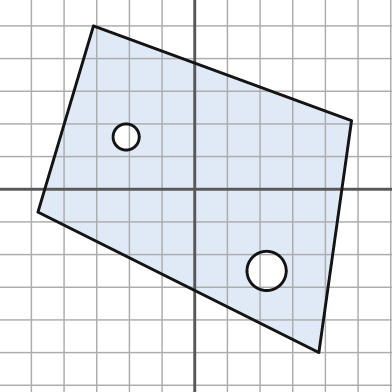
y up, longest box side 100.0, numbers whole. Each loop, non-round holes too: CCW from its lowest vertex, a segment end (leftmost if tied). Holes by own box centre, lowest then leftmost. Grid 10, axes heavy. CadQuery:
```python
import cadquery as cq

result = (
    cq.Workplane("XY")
    .moveTo(38.0, -50.0)
    .lineTo(48.0, 21.0)
    .lineTo(-31.0, 50.0)
    .lineTo(-48.0, -7.0)
    .close()
    .moveTo(22.0, -25.0)
    .circle(6.0)
    .moveTo(-21.0, 16.0)
    .circle(4.0)
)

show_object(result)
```